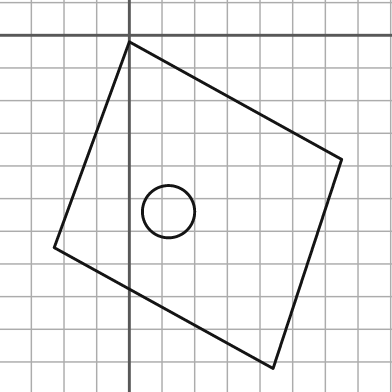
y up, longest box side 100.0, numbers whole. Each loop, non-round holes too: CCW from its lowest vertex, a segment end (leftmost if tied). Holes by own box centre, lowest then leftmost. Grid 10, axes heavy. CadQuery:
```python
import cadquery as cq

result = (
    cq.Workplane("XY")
    .moveTo(44.0, -102.0)
    .lineTo(65.0, -38.0)
    .lineTo(0.0, -2.0)
    .lineTo(-23.0, -65.0)
    .close()
    .moveTo(12.0, -54.0)
    .circle(8.0)
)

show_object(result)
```